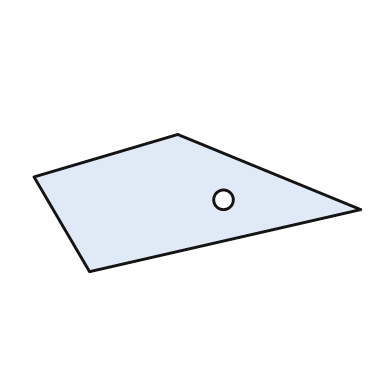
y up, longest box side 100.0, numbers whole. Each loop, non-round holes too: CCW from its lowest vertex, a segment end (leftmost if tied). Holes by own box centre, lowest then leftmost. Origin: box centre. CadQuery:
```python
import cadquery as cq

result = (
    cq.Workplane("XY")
    .moveTo(-33.0, -21.0)
    .lineTo(50.0, -2.0)
    .lineTo(-6.0, 21.0)
    .lineTo(-50.0, 8.0)
    .close()
    .moveTo(8.0, 1.0)
    .circle(3.0)
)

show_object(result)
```